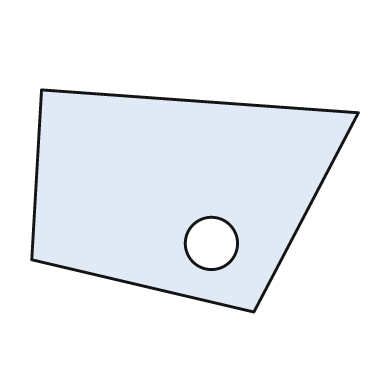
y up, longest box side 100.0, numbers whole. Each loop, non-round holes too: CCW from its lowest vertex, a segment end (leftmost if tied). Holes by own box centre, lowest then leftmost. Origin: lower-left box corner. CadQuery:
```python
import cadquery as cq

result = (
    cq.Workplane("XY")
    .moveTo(68.0, 0.0)
    .lineTo(100.0, 61.0)
    .lineTo(3.0, 68.0)
    .lineTo(0.0, 16.0)
    .close()
    .moveTo(55.0, 21.0)
    .circle(8.0)
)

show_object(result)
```